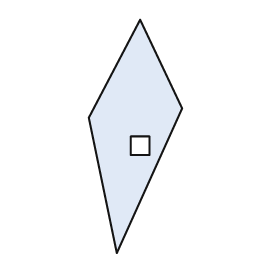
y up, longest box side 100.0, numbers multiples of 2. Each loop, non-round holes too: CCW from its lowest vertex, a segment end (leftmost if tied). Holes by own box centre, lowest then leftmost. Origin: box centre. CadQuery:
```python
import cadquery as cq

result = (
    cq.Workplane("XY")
    .moveTo(-8.0, -50.0)
    .lineTo(20.0, 12.0)
    .lineTo(2.0, 50.0)
    .lineTo(-20.0, 8.0)
    .close()
    .moveTo(-2.0, -8.0)
    .lineTo(6.0, -8.0)
    .lineTo(6.0, 0.0)
    .lineTo(-2.0, 0.0)
    .close()
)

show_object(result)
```